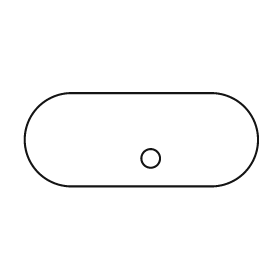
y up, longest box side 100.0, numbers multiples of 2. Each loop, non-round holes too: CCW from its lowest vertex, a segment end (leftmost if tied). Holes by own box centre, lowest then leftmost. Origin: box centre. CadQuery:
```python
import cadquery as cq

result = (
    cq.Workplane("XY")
    .moveTo(-30.0, -20.0)
    .lineTo(30.0, -20.0)
    .threePointArc((50.0, 0.0), (30.0, 20.0))
    .lineTo(-30.0, 20.0)
    .threePointArc((-50.0, 0.0), (-30.0, -20.0))
    .close()
    .moveTo(4.0, -8.0)
    .circle(4.0)
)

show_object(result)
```